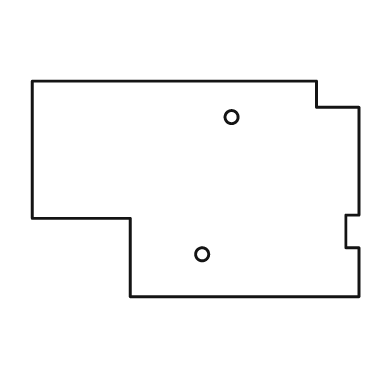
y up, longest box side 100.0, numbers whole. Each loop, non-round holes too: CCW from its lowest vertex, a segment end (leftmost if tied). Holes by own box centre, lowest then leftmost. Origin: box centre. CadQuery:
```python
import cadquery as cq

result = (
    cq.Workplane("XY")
    .moveTo(-20.0, -33.0)
    .lineTo(50.0, -33.0)
    .lineTo(50.0, -18.0)
    .lineTo(46.0, -18.0)
    .lineTo(46.0, -8.0)
    .lineTo(50.0, -8.0)
    .lineTo(50.0, 25.0)
    .lineTo(37.0, 25.0)
    .lineTo(37.0, 33.0)
    .lineTo(-50.0, 33.0)
    .lineTo(-50.0, -9.0)
    .lineTo(-20.0, -9.0)
    .close()
    .moveTo(2.0, -20.0)
    .circle(2.0)
    .moveTo(11.0, 22.0)
    .circle(2.0)
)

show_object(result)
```